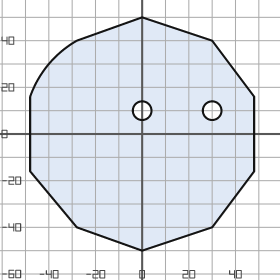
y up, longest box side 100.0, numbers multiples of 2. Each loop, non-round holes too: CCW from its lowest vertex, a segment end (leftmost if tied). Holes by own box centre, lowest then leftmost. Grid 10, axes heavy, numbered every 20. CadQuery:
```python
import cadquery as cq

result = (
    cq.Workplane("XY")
    .moveTo(0.0, -50.0)
    .lineTo(30.0, -40.0)
    .lineTo(48.0, -16.0)
    .lineTo(48.0, 16.0)
    .lineTo(30.0, 40.0)
    .lineTo(0.0, 50.0)
    .lineTo(-28.0, 40.0)
    .threePointArc((-40.0, 30.0), (-48.0, 16.0))
    .lineTo(-48.0, -16.0)
    .lineTo(-28.0, -40.0)
    .close()
    .moveTo(0.0, 10.0)
    .circle(4.0)
    .moveTo(30.0, 10.0)
    .circle(4.0)
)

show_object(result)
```